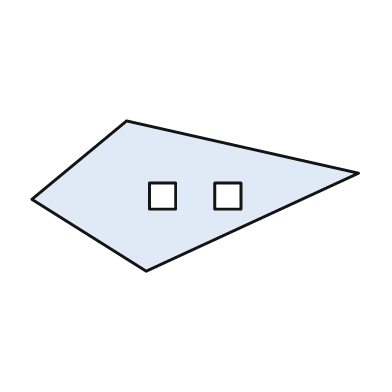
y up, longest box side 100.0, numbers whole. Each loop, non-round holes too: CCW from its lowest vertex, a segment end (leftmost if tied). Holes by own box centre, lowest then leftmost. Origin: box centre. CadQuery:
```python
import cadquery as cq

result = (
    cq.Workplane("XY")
    .moveTo(-15.0, -23.0)
    .lineTo(50.0, 7.0)
    .lineTo(-21.0, 23.0)
    .lineTo(-50.0, -1.0)
    .close()
    .moveTo(-14.0, -4.0)
    .lineTo(-6.0, -4.0)
    .lineTo(-6.0, 4.0)
    .lineTo(-14.0, 4.0)
    .close()
    .moveTo(6.0, -4.0)
    .lineTo(14.0, -4.0)
    .lineTo(14.0, 4.0)
    .lineTo(6.0, 4.0)
    .close()
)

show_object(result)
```